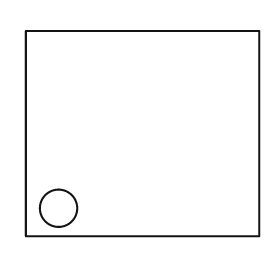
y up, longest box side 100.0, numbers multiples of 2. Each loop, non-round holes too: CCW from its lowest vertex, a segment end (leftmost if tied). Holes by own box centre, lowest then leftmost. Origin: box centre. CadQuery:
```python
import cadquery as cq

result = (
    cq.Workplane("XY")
    .moveTo(-50.0, -44.0)
    .lineTo(50.0, -44.0)
    .lineTo(50.0, 44.0)
    .lineTo(-50.0, 44.0)
    .close()
    .moveTo(-36.0, -32.0)
    .circle(8.0)
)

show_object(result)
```